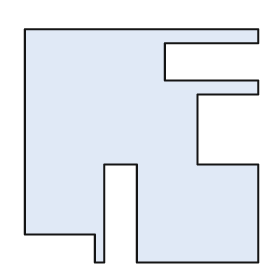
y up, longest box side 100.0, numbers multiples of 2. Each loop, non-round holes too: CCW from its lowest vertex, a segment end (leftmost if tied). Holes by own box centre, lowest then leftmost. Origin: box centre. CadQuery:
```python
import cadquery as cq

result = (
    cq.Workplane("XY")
    .moveTo(-20.0, -50.0)
    .lineTo(-16.0, -50.0)
    .lineTo(-16.0, -8.0)
    .lineTo(-2.0, -8.0)
    .lineTo(-2.0, -50.0)
    .lineTo(50.0, -50.0)
    .lineTo(50.0, -8.0)
    .lineTo(24.0, -8.0)
    .lineTo(24.0, 22.0)
    .lineTo(50.0, 22.0)
    .lineTo(50.0, 28.0)
    .lineTo(10.0, 28.0)
    .lineTo(10.0, 44.0)
    .lineTo(50.0, 44.0)
    .lineTo(50.0, 50.0)
    .lineTo(-50.0, 50.0)
    .lineTo(-50.0, -38.0)
    .lineTo(-20.0, -38.0)
    .close()
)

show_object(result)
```